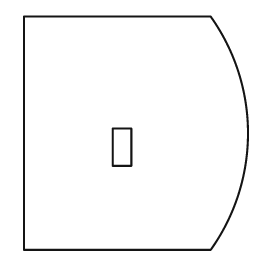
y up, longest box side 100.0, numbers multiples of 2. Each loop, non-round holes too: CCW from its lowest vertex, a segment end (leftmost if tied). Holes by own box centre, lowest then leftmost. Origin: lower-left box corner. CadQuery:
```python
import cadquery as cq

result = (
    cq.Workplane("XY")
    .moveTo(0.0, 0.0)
    .lineTo(80.0, 0.0)
    .threePointArc((96.0, 50.0), (80.0, 100.0))
    .lineTo(0.0, 100.0)
    .close()
    .moveTo(38.0, 36.0)
    .lineTo(46.0, 36.0)
    .lineTo(46.0, 52.0)
    .lineTo(38.0, 52.0)
    .close()
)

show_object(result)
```